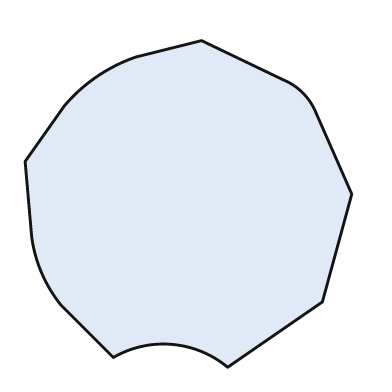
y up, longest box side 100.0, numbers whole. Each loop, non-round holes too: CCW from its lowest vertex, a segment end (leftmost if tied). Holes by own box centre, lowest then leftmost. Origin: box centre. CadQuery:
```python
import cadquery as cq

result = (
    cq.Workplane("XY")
    .moveTo(12.0, -50.0)
    .lineTo(41.0, -30.0)
    .lineTo(50.0, 3.0)
    .lineTo(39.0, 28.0)
    .threePointArc((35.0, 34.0), (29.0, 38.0))
    .lineTo(4.0, 50.0)
    .lineTo(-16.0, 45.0)
    .threePointArc((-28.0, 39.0), (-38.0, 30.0))
    .lineTo(-50.0, 13.0)
    .lineTo(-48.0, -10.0)
    .threePointArc((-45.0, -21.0), (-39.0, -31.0))
    .lineTo(-23.0, -47.0)
    .threePointArc((-5.0, -43.0), (12.0, -50.0))
    .close()
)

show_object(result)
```